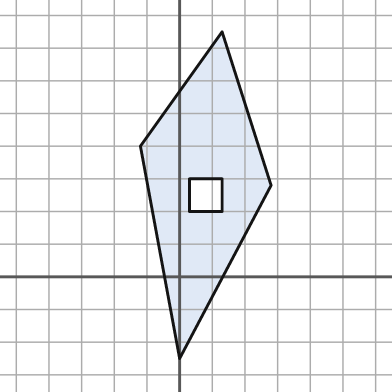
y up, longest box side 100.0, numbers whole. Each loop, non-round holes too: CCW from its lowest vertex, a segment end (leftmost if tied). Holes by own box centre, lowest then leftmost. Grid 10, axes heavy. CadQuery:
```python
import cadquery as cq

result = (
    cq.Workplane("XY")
    .moveTo(0.0, -25.0)
    .lineTo(28.0, 28.0)
    .lineTo(13.0, 75.0)
    .lineTo(-12.0, 40.0)
    .close()
    .moveTo(3.0, 20.0)
    .lineTo(13.0, 20.0)
    .lineTo(13.0, 30.0)
    .lineTo(3.0, 30.0)
    .close()
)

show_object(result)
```